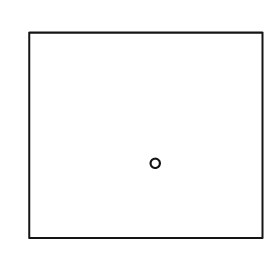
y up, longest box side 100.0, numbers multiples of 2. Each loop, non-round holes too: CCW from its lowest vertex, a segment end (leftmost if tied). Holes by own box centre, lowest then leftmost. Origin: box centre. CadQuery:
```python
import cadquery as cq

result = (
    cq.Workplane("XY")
    .moveTo(-50.0, -44.0)
    .lineTo(50.0, -44.0)
    .lineTo(50.0, 44.0)
    .lineTo(-50.0, 44.0)
    .close()
    .moveTo(4.0, -12.0)
    .circle(2.0)
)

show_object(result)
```